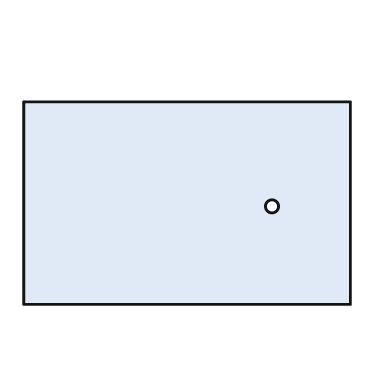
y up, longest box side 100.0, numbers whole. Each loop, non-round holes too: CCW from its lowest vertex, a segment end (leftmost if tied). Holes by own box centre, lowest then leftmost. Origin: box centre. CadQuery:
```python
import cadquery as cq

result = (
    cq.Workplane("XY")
    .moveTo(-50.0, -31.0)
    .lineTo(50.0, -31.0)
    .lineTo(50.0, 31.0)
    .lineTo(-50.0, 31.0)
    .close()
    .moveTo(26.0, -1.0)
    .circle(2.0)
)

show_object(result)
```